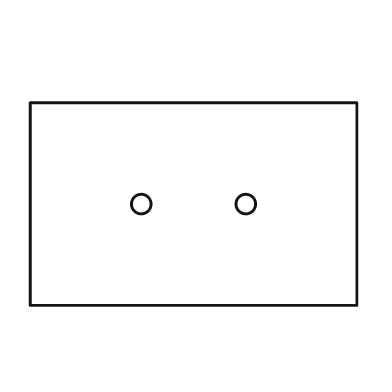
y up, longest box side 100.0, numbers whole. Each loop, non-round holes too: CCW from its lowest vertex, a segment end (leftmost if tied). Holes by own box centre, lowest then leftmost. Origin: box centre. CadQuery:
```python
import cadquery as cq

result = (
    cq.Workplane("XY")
    .moveTo(-50.0, -31.0)
    .lineTo(50.0, -31.0)
    .lineTo(50.0, 31.0)
    .lineTo(-50.0, 31.0)
    .close()
    .moveTo(-16.0, 0.0)
    .circle(3.0)
    .moveTo(16.0, 0.0)
    .circle(3.0)
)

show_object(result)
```